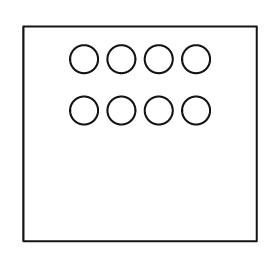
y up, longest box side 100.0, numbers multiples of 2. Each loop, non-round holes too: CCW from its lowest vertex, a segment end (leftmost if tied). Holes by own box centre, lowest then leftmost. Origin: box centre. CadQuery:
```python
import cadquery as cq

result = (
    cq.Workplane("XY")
    .moveTo(-50.0, -46.0)
    .lineTo(50.0, -46.0)
    .lineTo(50.0, 46.0)
    .lineTo(-50.0, 46.0)
    .close()
    .moveTo(-24.0, 10.0)
    .circle(6.0)
    .moveTo(-8.0, 10.0)
    .circle(6.0)
    .moveTo(8.0, 10.0)
    .circle(6.0)
    .moveTo(24.0, 10.0)
    .circle(6.0)
    .moveTo(-24.0, 32.0)
    .circle(6.0)
    .moveTo(-8.0, 32.0)
    .circle(6.0)
    .moveTo(8.0, 32.0)
    .circle(6.0)
    .moveTo(24.0, 32.0)
    .circle(6.0)
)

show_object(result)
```